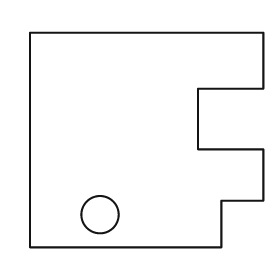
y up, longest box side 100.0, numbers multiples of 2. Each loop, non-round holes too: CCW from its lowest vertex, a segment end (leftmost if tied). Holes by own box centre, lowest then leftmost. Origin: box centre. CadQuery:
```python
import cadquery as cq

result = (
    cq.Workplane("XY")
    .moveTo(-50.0, -46.0)
    .lineTo(32.0, -46.0)
    .lineTo(32.0, -26.0)
    .lineTo(50.0, -26.0)
    .lineTo(50.0, -4.0)
    .lineTo(22.0, -4.0)
    .lineTo(22.0, 22.0)
    .lineTo(50.0, 22.0)
    .lineTo(50.0, 46.0)
    .lineTo(-50.0, 46.0)
    .close()
    .moveTo(-20.0, -32.0)
    .circle(8.0)
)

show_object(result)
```